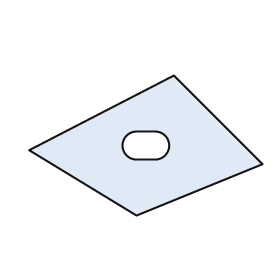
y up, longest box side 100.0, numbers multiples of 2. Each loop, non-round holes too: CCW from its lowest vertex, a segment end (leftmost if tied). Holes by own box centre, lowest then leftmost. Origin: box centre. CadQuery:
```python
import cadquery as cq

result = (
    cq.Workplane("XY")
    .moveTo(-4.0, -30.0)
    .lineTo(50.0, -8.0)
    .lineTo(12.0, 30.0)
    .lineTo(-50.0, -2.0)
    .close()
    .moveTo(-4.0, -6.0)
    .lineTo(4.0, -6.0)
    .threePointArc((10.0, 0.0), (4.0, 6.0))
    .lineTo(-4.0, 6.0)
    .threePointArc((-10.0, 0.0), (-4.0, -6.0))
    .close()
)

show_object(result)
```